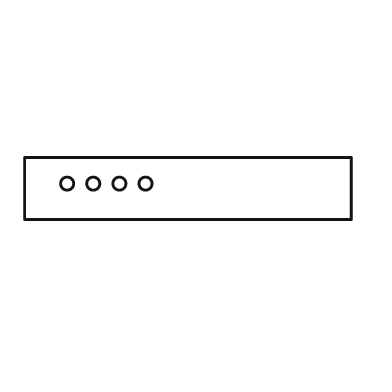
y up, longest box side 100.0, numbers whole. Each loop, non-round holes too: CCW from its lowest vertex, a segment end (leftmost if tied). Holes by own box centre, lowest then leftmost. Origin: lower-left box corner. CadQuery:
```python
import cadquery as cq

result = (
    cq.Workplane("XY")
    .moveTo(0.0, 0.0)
    .lineTo(100.0, 0.0)
    .lineTo(100.0, 19.0)
    .lineTo(0.0, 19.0)
    .close()
    .moveTo(13.0, 11.0)
    .circle(2.0)
    .moveTo(21.0, 11.0)
    .circle(2.0)
    .moveTo(29.0, 11.0)
    .circle(2.0)
    .moveTo(37.0, 11.0)
    .circle(2.0)
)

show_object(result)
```